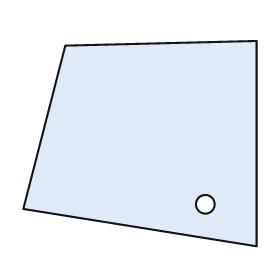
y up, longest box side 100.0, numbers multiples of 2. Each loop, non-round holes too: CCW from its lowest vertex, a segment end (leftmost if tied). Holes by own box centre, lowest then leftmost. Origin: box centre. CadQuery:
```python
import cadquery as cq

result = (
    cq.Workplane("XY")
    .moveTo(50.0, -44.0)
    .lineTo(50.0, 44.0)
    .lineTo(-32.0, 42.0)
    .lineTo(-50.0, -28.0)
    .close()
    .moveTo(28.0, -26.0)
    .circle(4.0)
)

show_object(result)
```